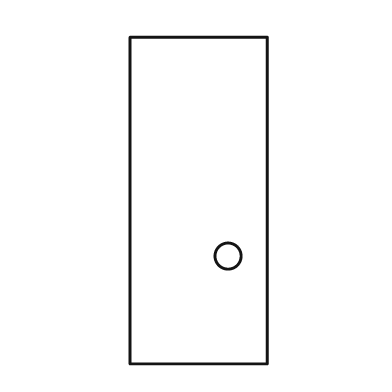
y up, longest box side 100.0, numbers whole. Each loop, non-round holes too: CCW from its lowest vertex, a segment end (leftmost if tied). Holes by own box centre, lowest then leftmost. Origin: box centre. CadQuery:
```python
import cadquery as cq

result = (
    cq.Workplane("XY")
    .moveTo(-21.0, -50.0)
    .lineTo(21.0, -50.0)
    .lineTo(21.0, 50.0)
    .lineTo(-21.0, 50.0)
    .close()
    .moveTo(9.0, -17.0)
    .circle(4.0)
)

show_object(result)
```